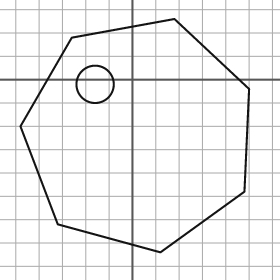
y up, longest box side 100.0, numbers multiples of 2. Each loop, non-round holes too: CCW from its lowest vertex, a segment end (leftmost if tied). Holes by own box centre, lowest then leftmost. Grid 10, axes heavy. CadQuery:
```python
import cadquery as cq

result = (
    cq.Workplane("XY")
    .moveTo(12.0, -74.0)
    .lineTo(48.0, -48.0)
    .lineTo(50.0, -4.0)
    .lineTo(18.0, 26.0)
    .lineTo(-26.0, 18.0)
    .lineTo(-48.0, -20.0)
    .lineTo(-32.0, -62.0)
    .close()
    .moveTo(-16.0, -2.0)
    .circle(8.0)
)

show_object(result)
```